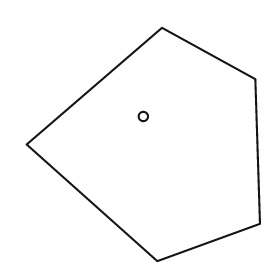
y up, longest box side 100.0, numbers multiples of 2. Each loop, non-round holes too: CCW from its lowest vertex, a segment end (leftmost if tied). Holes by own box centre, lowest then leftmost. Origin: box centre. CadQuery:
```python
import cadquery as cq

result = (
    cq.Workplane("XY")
    .moveTo(6.0, -50.0)
    .lineTo(50.0, -34.0)
    .lineTo(48.0, 28.0)
    .lineTo(8.0, 50.0)
    .lineTo(-50.0, 0.0)
    .close()
    .moveTo(0.0, 12.0)
    .circle(2.0)
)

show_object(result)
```